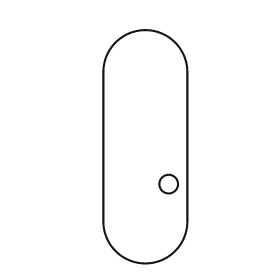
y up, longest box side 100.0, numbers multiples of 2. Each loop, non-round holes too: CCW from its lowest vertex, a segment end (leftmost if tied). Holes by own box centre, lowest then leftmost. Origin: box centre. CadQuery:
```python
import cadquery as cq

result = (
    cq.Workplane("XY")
    .moveTo(-18.0, -32.0)
    .threePointArc((0.0, -50.0), (18.0, -32.0))
    .lineTo(18.0, 32.0)
    .threePointArc((0.0, 50.0), (-18.0, 32.0))
    .close()
    .moveTo(10.0, -16.0)
    .circle(4.0)
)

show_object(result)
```